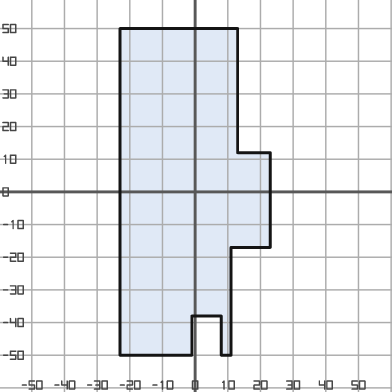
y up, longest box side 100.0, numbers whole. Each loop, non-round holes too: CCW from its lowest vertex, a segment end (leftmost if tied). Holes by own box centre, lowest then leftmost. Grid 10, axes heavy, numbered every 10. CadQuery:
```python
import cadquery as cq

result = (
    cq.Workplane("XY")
    .moveTo(-23.0, -50.0)
    .lineTo(-1.0, -50.0)
    .lineTo(-1.0, -38.0)
    .lineTo(8.0, -38.0)
    .lineTo(8.0, -50.0)
    .lineTo(11.0, -50.0)
    .lineTo(11.0, -17.0)
    .lineTo(23.0, -17.0)
    .lineTo(23.0, 12.0)
    .lineTo(13.0, 12.0)
    .lineTo(13.0, 50.0)
    .lineTo(-23.0, 50.0)
    .close()
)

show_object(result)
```